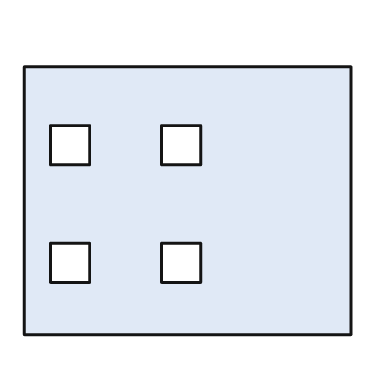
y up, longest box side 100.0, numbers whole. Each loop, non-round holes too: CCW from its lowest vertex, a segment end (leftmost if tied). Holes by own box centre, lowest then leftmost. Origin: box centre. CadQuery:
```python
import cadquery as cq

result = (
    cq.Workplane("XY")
    .moveTo(-50.0, -41.0)
    .lineTo(50.0, -41.0)
    .lineTo(50.0, 41.0)
    .lineTo(-50.0, 41.0)
    .close()
    .moveTo(-42.0, -25.0)
    .lineTo(-30.0, -25.0)
    .lineTo(-30.0, -13.0)
    .lineTo(-42.0, -13.0)
    .close()
    .moveTo(-8.0, -25.0)
    .lineTo(4.0, -25.0)
    .lineTo(4.0, -13.0)
    .lineTo(-8.0, -13.0)
    .close()
    .moveTo(-42.0, 11.0)
    .lineTo(-30.0, 11.0)
    .lineTo(-30.0, 23.0)
    .lineTo(-42.0, 23.0)
    .close()
    .moveTo(-8.0, 11.0)
    .lineTo(4.0, 11.0)
    .lineTo(4.0, 23.0)
    .lineTo(-8.0, 23.0)
    .close()
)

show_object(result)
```